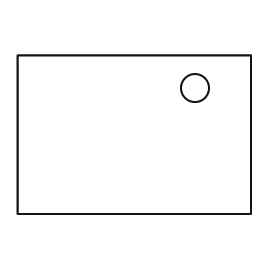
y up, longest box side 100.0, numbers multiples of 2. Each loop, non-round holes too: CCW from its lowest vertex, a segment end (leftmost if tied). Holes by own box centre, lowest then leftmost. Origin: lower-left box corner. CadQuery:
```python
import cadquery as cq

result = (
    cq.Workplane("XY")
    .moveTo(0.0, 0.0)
    .lineTo(100.0, 0.0)
    .lineTo(100.0, 68.0)
    .lineTo(0.0, 68.0)
    .close()
    .moveTo(76.0, 54.0)
    .circle(6.0)
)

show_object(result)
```